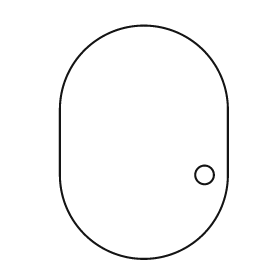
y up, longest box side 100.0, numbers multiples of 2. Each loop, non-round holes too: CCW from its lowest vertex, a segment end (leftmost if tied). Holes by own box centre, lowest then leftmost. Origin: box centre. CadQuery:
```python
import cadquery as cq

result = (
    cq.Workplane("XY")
    .moveTo(-36.0, -14.0)
    .threePointArc((0.0, -50.0), (36.0, -14.0))
    .lineTo(36.0, 14.0)
    .threePointArc((0.0, 50.0), (-36.0, 14.0))
    .close()
    .moveTo(26.0, -14.0)
    .circle(4.0)
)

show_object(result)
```